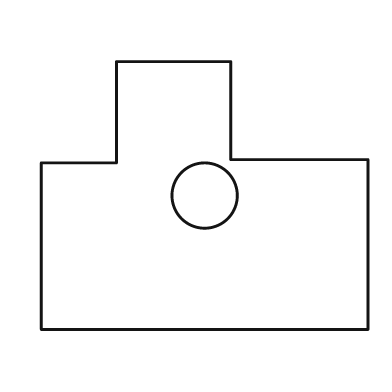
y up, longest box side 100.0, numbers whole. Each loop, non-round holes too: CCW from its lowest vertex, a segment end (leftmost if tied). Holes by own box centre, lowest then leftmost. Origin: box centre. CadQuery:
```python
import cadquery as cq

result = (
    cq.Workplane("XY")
    .moveTo(-50.0, -41.0)
    .lineTo(50.0, -41.0)
    .lineTo(50.0, 11.0)
    .lineTo(8.0, 11.0)
    .lineTo(8.0, 41.0)
    .lineTo(-27.0, 41.0)
    .lineTo(-27.0, 10.0)
    .lineTo(-50.0, 10.0)
    .close()
    .moveTo(0.0, 0.0)
    .circle(10.0)
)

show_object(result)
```